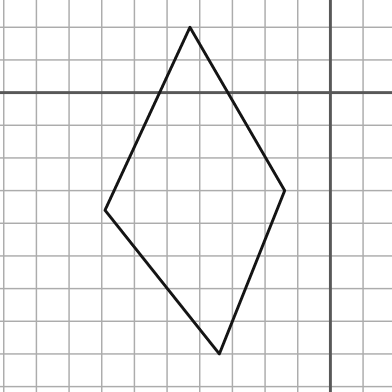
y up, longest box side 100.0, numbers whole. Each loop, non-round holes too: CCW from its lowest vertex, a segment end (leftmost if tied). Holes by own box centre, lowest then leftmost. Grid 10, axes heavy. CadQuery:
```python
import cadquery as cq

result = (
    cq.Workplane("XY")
    .moveTo(-34.0, -80.0)
    .lineTo(-14.0, -30.0)
    .lineTo(-43.0, 20.0)
    .lineTo(-69.0, -36.0)
    .close()
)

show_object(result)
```